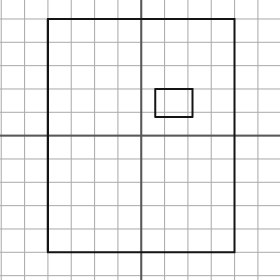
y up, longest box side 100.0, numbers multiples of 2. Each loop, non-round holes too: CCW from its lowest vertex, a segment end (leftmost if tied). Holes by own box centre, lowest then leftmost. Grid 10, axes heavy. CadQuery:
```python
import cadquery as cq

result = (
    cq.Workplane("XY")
    .moveTo(-40.0, -50.0)
    .lineTo(40.0, -50.0)
    .lineTo(40.0, 50.0)
    .lineTo(-40.0, 50.0)
    .close()
    .moveTo(6.0, 8.0)
    .lineTo(22.0, 8.0)
    .lineTo(22.0, 20.0)
    .lineTo(6.0, 20.0)
    .close()
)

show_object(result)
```